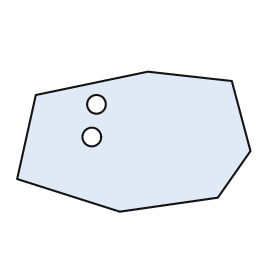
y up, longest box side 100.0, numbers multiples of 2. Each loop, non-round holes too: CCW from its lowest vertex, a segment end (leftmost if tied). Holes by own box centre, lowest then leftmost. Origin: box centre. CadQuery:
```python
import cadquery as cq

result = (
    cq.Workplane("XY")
    .moveTo(-6.0, -30.0)
    .lineTo(36.0, -24.0)
    .lineTo(50.0, -4.0)
    .lineTo(42.0, 26.0)
    .lineTo(6.0, 30.0)
    .lineTo(-42.0, 20.0)
    .lineTo(-50.0, -16.0)
    .close()
    .moveTo(-18.0, 2.0)
    .circle(4.0)
    .moveTo(-16.0, 16.0)
    .circle(4.0)
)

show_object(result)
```